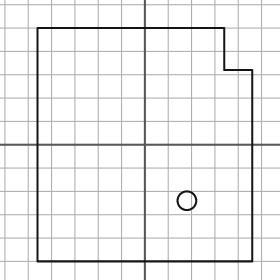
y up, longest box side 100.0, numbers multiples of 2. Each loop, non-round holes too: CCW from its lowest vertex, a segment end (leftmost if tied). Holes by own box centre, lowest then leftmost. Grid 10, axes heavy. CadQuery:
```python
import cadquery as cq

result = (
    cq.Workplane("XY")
    .moveTo(-46.0, -50.0)
    .lineTo(46.0, -50.0)
    .lineTo(46.0, 32.0)
    .lineTo(34.0, 32.0)
    .lineTo(34.0, 50.0)
    .lineTo(-46.0, 50.0)
    .close()
    .moveTo(18.0, -24.0)
    .circle(4.0)
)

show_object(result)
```